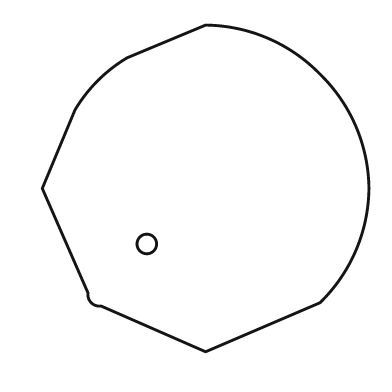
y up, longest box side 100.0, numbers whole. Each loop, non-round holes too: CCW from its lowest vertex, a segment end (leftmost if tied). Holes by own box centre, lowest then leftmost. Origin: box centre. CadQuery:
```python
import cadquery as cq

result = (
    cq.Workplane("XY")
    .moveTo(0.0, -50.0)
    .lineTo(35.0, -35.0)
    .threePointArc((46.0, -19.0), (50.0, 0.0))
    .threePointArc((46.0, 19.0), (35.0, 35.0))
    .threePointArc((19.0, 46.0), (0.0, 50.0))
    .lineTo(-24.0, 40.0)
    .threePointArc((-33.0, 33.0), (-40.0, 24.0))
    .lineTo(-50.0, 0.0)
    .lineTo(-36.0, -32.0)
    .threePointArc((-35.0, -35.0), (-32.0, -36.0))
    .close()
    .moveTo(-18.0, -17.0)
    .circle(3.0)
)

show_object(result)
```